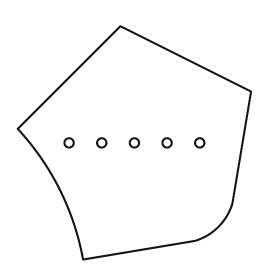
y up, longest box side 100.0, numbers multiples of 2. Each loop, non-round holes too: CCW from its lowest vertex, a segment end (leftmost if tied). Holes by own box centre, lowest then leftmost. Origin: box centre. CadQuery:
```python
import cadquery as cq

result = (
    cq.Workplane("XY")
    .moveTo(-22.0, -50.0)
    .lineTo(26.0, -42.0)
    .threePointArc((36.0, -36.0), (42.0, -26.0))
    .lineTo(50.0, 22.0)
    .lineTo(-6.0, 50.0)
    .lineTo(-50.0, 6.0)
    .threePointArc((-32.0, -20.0), (-22.0, -50.0))
    .close()
    .moveTo(-28.0, 0.0)
    .circle(2.0)
    .moveTo(-14.0, 0.0)
    .circle(2.0)
    .moveTo(0.0, 0.0)
    .circle(2.0)
    .moveTo(14.0, 0.0)
    .circle(2.0)
    .moveTo(28.0, 0.0)
    .circle(2.0)
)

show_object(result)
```